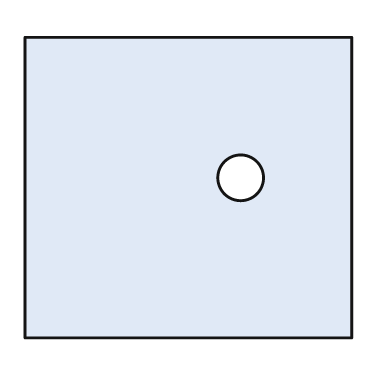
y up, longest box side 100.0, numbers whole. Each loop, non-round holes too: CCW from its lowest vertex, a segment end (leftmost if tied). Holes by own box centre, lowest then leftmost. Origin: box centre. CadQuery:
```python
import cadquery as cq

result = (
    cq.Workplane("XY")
    .moveTo(-50.0, -46.0)
    .lineTo(50.0, -46.0)
    .lineTo(50.0, 46.0)
    .lineTo(-50.0, 46.0)
    .close()
    .moveTo(16.0, 3.0)
    .circle(7.0)
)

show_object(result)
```